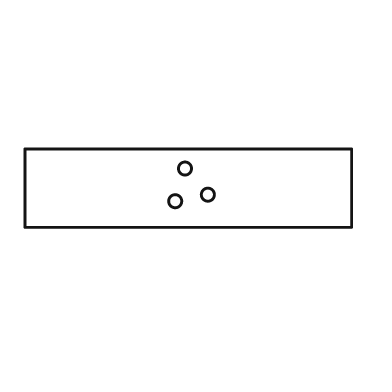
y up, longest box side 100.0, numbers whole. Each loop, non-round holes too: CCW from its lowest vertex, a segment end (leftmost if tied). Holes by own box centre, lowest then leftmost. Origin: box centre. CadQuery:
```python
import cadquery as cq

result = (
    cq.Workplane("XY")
    .moveTo(-50.0, -12.0)
    .lineTo(50.0, -12.0)
    .lineTo(50.0, 12.0)
    .lineTo(-50.0, 12.0)
    .close()
    .moveTo(-4.0, -4.0)
    .circle(2.0)
    .moveTo(6.0, -2.0)
    .circle(2.0)
    .moveTo(-1.0, 6.0)
    .circle(2.0)
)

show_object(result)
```